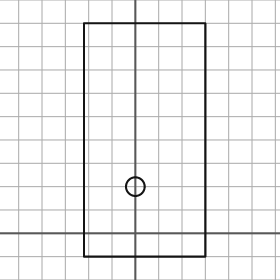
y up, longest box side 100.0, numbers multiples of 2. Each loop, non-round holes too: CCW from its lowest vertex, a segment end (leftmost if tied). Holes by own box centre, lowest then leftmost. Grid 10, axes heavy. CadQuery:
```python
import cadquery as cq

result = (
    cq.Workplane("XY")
    .moveTo(-22.0, -10.0)
    .lineTo(30.0, -10.0)
    .lineTo(30.0, 90.0)
    .lineTo(-22.0, 90.0)
    .close()
    .moveTo(0.0, 20.0)
    .circle(4.0)
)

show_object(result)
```